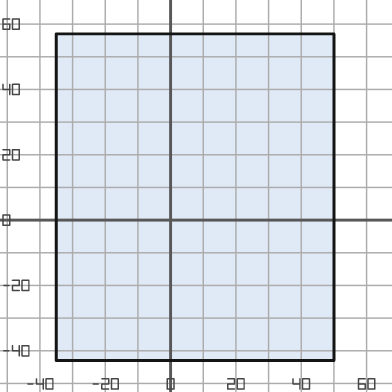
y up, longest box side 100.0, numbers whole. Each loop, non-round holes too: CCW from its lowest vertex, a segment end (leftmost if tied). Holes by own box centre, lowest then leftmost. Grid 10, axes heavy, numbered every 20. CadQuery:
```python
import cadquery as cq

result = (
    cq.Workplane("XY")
    .moveTo(-35.0, -43.0)
    .lineTo(50.0, -43.0)
    .lineTo(50.0, 57.0)
    .lineTo(-35.0, 57.0)
    .close()
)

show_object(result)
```